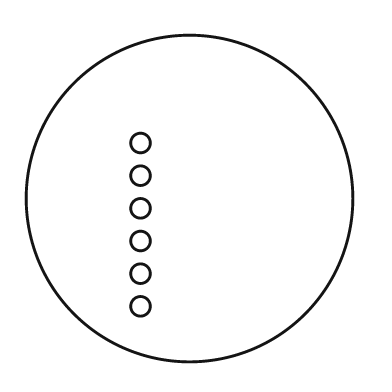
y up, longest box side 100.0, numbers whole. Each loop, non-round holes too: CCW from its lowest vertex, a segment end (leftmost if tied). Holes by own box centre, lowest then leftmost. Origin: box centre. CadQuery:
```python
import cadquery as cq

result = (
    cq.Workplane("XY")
    .moveTo(0.0, 0.0)
    .circle(50.0)
    .moveTo(-15.0, -33.0)
    .circle(3.0)
    .moveTo(-15.0, -23.0)
    .circle(3.0)
    .moveTo(-15.0, -13.0)
    .circle(3.0)
    .moveTo(-15.0, -3.0)
    .circle(3.0)
    .moveTo(-15.0, 7.0)
    .circle(3.0)
    .moveTo(-15.0, 17.0)
    .circle(3.0)
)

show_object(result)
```